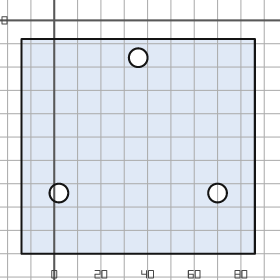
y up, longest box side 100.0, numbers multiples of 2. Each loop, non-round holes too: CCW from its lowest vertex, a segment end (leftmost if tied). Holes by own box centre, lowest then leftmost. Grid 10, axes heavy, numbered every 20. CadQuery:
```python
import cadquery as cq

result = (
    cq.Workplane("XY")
    .moveTo(-14.0, -100.0)
    .lineTo(86.0, -100.0)
    .lineTo(86.0, -8.0)
    .lineTo(-14.0, -8.0)
    .close()
    .moveTo(2.0, -74.0)
    .circle(4.0)
    .moveTo(70.0, -74.0)
    .circle(4.0)
    .moveTo(36.0, -16.0)
    .circle(4.0)
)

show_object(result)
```